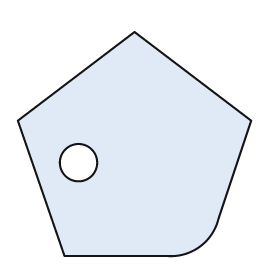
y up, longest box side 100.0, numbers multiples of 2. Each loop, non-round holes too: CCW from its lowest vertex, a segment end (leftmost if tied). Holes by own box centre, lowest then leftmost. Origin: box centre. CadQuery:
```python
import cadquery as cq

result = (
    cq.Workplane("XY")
    .moveTo(-30.0, -48.0)
    .lineTo(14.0, -48.0)
    .threePointArc((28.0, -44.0), (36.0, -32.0))
    .lineTo(50.0, 10.0)
    .lineTo(0.0, 48.0)
    .lineTo(-50.0, 10.0)
    .close()
    .moveTo(-24.0, -8.0)
    .circle(8.0)
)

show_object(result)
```